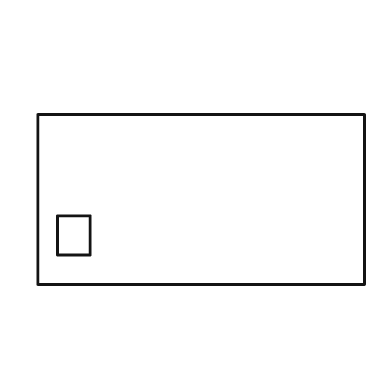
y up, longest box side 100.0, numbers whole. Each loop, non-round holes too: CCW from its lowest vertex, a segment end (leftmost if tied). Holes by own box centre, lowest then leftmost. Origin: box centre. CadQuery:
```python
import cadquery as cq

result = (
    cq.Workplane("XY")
    .moveTo(-50.0, -26.0)
    .lineTo(50.0, -26.0)
    .lineTo(50.0, 26.0)
    .lineTo(-50.0, 26.0)
    .close()
    .moveTo(-44.0, -17.0)
    .lineTo(-34.0, -17.0)
    .lineTo(-34.0, -5.0)
    .lineTo(-44.0, -5.0)
    .close()
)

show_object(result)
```